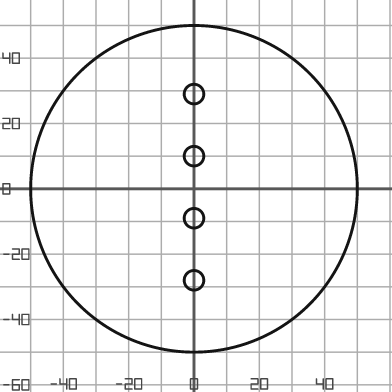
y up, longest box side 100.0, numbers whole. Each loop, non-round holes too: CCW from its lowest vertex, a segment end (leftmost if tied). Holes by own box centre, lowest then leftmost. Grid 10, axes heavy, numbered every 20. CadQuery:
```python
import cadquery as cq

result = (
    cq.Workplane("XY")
    .moveTo(0.0, 0.0)
    .circle(50.0)
    .moveTo(0.0, -28.0)
    .circle(3.0)
    .moveTo(0.0, -9.0)
    .circle(3.0)
    .moveTo(0.0, 10.0)
    .circle(3.0)
    .moveTo(0.0, 29.0)
    .circle(3.0)
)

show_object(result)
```